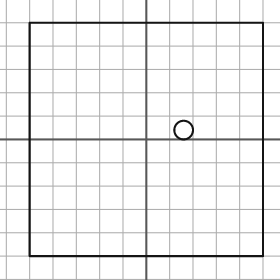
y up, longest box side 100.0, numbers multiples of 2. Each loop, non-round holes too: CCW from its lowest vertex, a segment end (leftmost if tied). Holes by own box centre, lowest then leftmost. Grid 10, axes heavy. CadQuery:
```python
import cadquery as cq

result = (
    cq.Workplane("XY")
    .moveTo(-50.0, -50.0)
    .lineTo(50.0, -50.0)
    .lineTo(50.0, 50.0)
    .lineTo(-50.0, 50.0)
    .close()
    .moveTo(16.0, 4.0)
    .circle(4.0)
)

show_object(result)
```